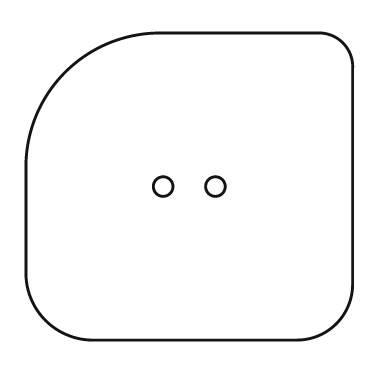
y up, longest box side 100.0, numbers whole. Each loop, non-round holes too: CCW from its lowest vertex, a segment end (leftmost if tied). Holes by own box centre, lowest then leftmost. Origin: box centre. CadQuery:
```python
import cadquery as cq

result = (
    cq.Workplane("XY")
    .moveTo(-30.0, -47.0)
    .lineTo(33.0, -47.0)
    .threePointArc((45.0, -42.0), (50.0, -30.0))
    .lineTo(50.0, 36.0)
    .threePointArc((47.0, 44.0), (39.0, 47.0))
    .lineTo(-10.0, 47.0)
    .threePointArc((-38.0, 35.0), (-50.0, 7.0))
    .lineTo(-50.0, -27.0)
    .threePointArc((-44.0, -41.0), (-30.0, -47.0))
    .close()
    .moveTo(-8.0, 0.0)
    .circle(3.0)
    .moveTo(8.0, 0.0)
    .circle(3.0)
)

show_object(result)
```